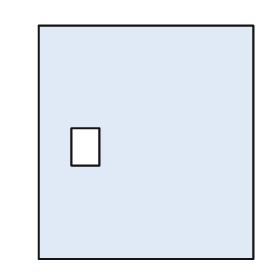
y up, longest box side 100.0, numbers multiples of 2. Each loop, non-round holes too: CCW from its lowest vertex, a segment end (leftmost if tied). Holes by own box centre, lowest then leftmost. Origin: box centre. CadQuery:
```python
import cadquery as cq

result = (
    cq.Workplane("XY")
    .moveTo(-46.0, -50.0)
    .lineTo(46.0, -50.0)
    .lineTo(46.0, 50.0)
    .lineTo(-46.0, 50.0)
    .close()
    .moveTo(-32.0, -10.0)
    .lineTo(-20.0, -10.0)
    .lineTo(-20.0, 6.0)
    .lineTo(-32.0, 6.0)
    .close()
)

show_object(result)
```